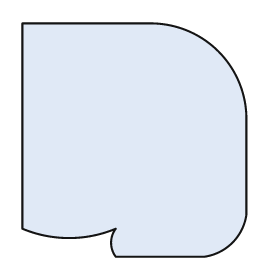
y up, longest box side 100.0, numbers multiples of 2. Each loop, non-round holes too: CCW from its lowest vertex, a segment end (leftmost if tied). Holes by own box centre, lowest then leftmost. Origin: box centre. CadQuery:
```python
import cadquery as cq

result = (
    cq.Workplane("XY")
    .moveTo(-8.0, -50.0)
    .lineTo(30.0, -50.0)
    .threePointArc((42.0, -44.0), (48.0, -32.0))
    .lineTo(48.0, 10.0)
    .threePointArc((36.0, 38.0), (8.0, 50.0))
    .lineTo(-48.0, 50.0)
    .lineTo(-48.0, -38.0)
    .threePointArc((-28.0, -42.0), (-8.0, -38.0))
    .threePointArc((-10.0, -44.0), (-8.0, -50.0))
    .close()
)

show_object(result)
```